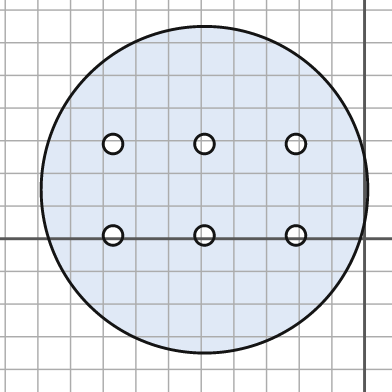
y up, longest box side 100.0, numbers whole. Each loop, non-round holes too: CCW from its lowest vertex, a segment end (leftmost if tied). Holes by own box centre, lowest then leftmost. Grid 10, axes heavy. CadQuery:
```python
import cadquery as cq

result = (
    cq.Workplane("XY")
    .moveTo(-49.0, 15.0)
    .circle(50.0)
    .moveTo(-77.0, 1.0)
    .circle(3.0)
    .moveTo(-49.0, 1.0)
    .circle(3.0)
    .moveTo(-21.0, 1.0)
    .circle(3.0)
    .moveTo(-77.0, 29.0)
    .circle(3.0)
    .moveTo(-49.0, 29.0)
    .circle(3.0)
    .moveTo(-21.0, 29.0)
    .circle(3.0)
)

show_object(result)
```